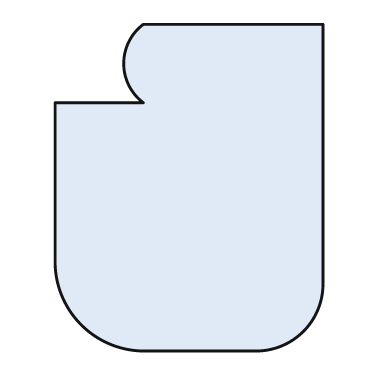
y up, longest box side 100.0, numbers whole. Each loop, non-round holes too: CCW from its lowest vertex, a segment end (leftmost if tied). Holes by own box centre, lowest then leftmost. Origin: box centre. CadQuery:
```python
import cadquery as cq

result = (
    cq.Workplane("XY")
    .moveTo(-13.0, -50.0)
    .lineTo(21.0, -50.0)
    .threePointArc((35.0, -44.0), (41.0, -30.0))
    .lineTo(41.0, 50.0)
    .lineTo(-14.0, 50.0)
    .threePointArc((-20.0, 38.0), (-14.0, 26.0))
    .lineTo(-41.0, 26.0)
    .lineTo(-41.0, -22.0)
    .threePointArc((-33.0, -42.0), (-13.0, -50.0))
    .close()
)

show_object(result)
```